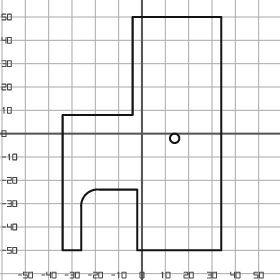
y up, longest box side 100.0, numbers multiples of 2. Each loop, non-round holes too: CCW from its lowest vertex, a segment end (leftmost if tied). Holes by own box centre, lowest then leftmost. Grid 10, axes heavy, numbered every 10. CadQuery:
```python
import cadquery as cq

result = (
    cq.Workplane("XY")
    .moveTo(-34.0, -50.0)
    .lineTo(-26.0, -50.0)
    .lineTo(-26.0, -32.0)
    .threePointArc((-24.0, -26.0), (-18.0, -24.0))
    .lineTo(-2.0, -24.0)
    .lineTo(-2.0, -50.0)
    .lineTo(34.0, -50.0)
    .lineTo(34.0, 50.0)
    .lineTo(-4.0, 50.0)
    .lineTo(-4.0, 8.0)
    .lineTo(-34.0, 8.0)
    .close()
    .moveTo(14.0, -2.0)
    .circle(2.0)
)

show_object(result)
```